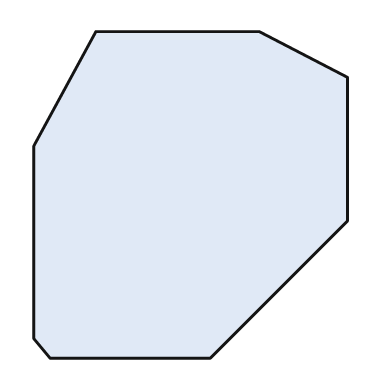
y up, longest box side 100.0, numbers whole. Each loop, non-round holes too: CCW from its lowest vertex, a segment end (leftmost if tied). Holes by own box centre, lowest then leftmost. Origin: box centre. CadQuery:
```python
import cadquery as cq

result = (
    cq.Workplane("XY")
    .moveTo(-43.0, -50.0)
    .lineTo(6.0, -50.0)
    .lineTo(48.0, -8.0)
    .lineTo(48.0, 36.0)
    .lineTo(21.0, 50.0)
    .lineTo(-29.0, 50.0)
    .lineTo(-48.0, 15.0)
    .lineTo(-48.0, -44.0)
    .close()
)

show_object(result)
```